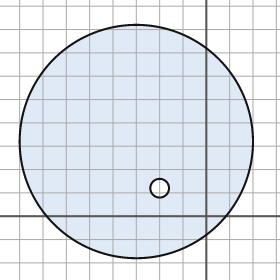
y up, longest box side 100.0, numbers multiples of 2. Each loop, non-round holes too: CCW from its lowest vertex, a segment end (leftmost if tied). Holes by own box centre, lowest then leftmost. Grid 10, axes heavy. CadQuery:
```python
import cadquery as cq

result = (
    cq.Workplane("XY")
    .moveTo(-30.0, 32.0)
    .circle(50.0)
    .moveTo(-20.0, 12.0)
    .circle(4.0)
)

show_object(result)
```